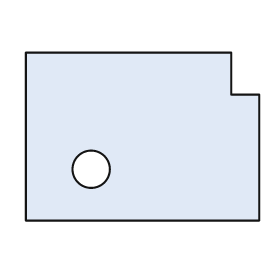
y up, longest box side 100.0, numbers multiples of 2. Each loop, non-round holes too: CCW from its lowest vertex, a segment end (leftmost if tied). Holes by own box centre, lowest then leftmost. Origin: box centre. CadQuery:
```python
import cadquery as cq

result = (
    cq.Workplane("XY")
    .moveTo(-50.0, -36.0)
    .lineTo(50.0, -36.0)
    .lineTo(50.0, 18.0)
    .lineTo(38.0, 18.0)
    .lineTo(38.0, 36.0)
    .lineTo(-50.0, 36.0)
    .close()
    .moveTo(-22.0, -14.0)
    .circle(8.0)
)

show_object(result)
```